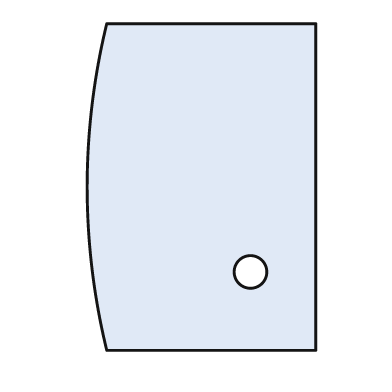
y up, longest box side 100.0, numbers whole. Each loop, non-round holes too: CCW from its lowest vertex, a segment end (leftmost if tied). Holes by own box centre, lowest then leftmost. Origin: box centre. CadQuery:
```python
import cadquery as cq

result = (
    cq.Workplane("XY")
    .moveTo(-29.0, -50.0)
    .lineTo(35.0, -50.0)
    .lineTo(35.0, 50.0)
    .lineTo(-29.0, 50.0)
    .threePointArc((-35.0, 0.0), (-29.0, -50.0))
    .close()
    .moveTo(15.0, -26.0)
    .circle(5.0)
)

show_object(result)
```